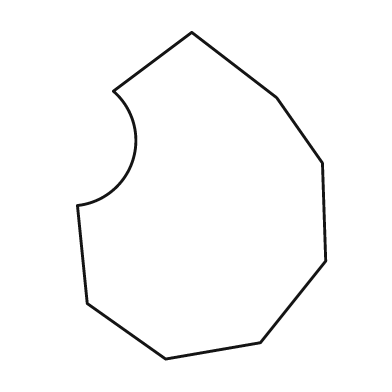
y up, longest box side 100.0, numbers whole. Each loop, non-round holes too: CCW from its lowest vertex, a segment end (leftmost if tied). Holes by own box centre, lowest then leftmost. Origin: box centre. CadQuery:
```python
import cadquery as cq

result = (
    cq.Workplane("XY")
    .moveTo(-11.0, -50.0)
    .lineTo(18.0, -45.0)
    .lineTo(38.0, -20.0)
    .lineTo(37.0, 10.0)
    .lineTo(23.0, 30.0)
    .lineTo(-3.0, 50.0)
    .lineTo(-27.0, 32.0)
    .threePointArc((-21.0, 11.0), (-38.0, -3.0))
    .lineTo(-35.0, -33.0)
    .close()
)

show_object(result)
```